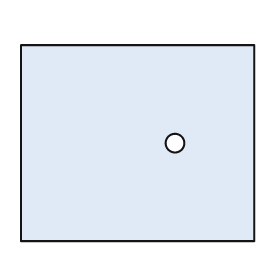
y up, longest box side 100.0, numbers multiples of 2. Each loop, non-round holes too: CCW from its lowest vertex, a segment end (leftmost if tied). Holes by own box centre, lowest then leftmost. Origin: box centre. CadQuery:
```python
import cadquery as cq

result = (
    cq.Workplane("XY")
    .moveTo(-50.0, -42.0)
    .lineTo(50.0, -42.0)
    .lineTo(50.0, 42.0)
    .lineTo(-50.0, 42.0)
    .close()
    .moveTo(16.0, 0.0)
    .circle(4.0)
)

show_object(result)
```